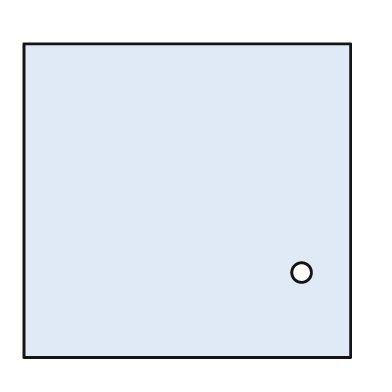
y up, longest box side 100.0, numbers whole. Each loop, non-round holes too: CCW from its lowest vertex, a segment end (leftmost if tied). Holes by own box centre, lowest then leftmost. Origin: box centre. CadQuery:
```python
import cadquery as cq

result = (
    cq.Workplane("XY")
    .moveTo(-50.0, -48.0)
    .lineTo(50.0, -48.0)
    .lineTo(50.0, 48.0)
    .lineTo(-50.0, 48.0)
    .close()
    .moveTo(35.0, -22.0)
    .circle(3.0)
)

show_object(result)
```